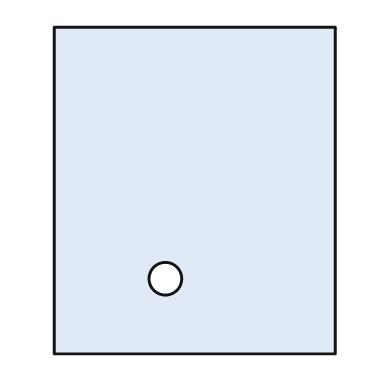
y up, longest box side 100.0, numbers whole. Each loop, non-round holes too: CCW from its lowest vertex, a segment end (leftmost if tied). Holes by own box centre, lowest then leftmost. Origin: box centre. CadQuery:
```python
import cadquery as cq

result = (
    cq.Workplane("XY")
    .moveTo(-43.0, -50.0)
    .lineTo(43.0, -50.0)
    .lineTo(43.0, 50.0)
    .lineTo(-43.0, 50.0)
    .close()
    .moveTo(-9.0, -27.0)
    .circle(5.0)
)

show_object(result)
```